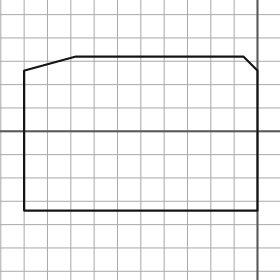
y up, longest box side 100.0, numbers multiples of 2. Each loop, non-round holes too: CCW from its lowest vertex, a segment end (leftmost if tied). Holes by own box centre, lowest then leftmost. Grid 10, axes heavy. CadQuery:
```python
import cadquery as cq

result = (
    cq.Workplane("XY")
    .moveTo(-100.0, -34.0)
    .lineTo(0.0, -34.0)
    .lineTo(0.0, 26.0)
    .lineTo(-6.0, 32.0)
    .lineTo(-78.0, 32.0)
    .lineTo(-100.0, 26.0)
    .close()
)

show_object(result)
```